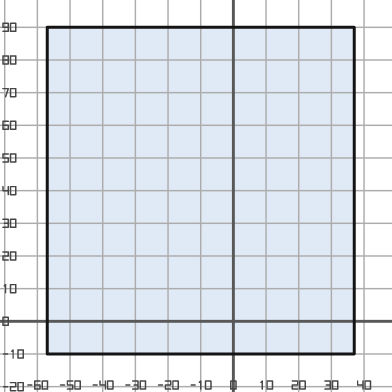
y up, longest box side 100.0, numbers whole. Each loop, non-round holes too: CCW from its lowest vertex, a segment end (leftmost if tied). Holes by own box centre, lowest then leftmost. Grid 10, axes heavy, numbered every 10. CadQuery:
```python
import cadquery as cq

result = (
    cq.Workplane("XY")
    .moveTo(-57.0, -10.0)
    .lineTo(37.0, -10.0)
    .lineTo(37.0, 90.0)
    .lineTo(-57.0, 90.0)
    .close()
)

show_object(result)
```